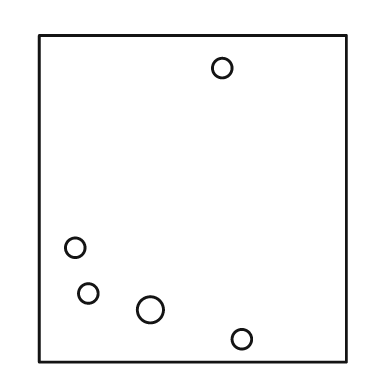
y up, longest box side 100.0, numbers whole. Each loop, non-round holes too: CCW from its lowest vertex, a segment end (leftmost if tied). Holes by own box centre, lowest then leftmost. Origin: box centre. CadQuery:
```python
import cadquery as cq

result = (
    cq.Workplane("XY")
    .moveTo(-47.0, -50.0)
    .lineTo(47.0, -50.0)
    .lineTo(47.0, 50.0)
    .lineTo(-47.0, 50.0)
    .close()
    .moveTo(15.0, -43.0)
    .circle(3.0)
    .moveTo(-13.0, -34.0)
    .circle(4.0)
    .moveTo(-32.0, -29.0)
    .circle(3.0)
    .moveTo(-36.0, -15.0)
    .circle(3.0)
    .moveTo(9.0, 40.0)
    .circle(3.0)
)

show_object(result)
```